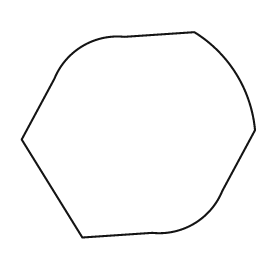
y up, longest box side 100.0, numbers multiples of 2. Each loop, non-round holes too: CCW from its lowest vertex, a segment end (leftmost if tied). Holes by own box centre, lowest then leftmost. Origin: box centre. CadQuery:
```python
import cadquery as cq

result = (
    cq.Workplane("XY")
    .moveTo(-24.0, -44.0)
    .lineTo(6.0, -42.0)
    .threePointArc((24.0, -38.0), (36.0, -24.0))
    .lineTo(50.0, 2.0)
    .threePointArc((42.0, 26.0), (24.0, 44.0))
    .lineTo(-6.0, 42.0)
    .threePointArc((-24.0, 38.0), (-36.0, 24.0))
    .lineTo(-50.0, -2.0)
    .close()
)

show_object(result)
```